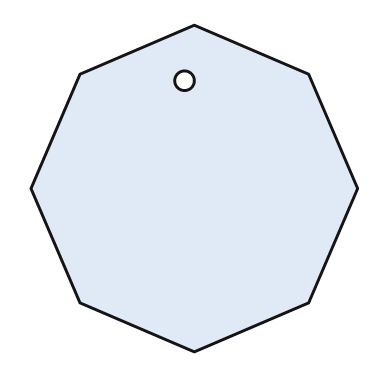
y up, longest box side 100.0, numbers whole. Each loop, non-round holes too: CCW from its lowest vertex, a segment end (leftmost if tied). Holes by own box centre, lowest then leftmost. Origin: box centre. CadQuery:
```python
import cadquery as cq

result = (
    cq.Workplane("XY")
    .moveTo(0.0, -50.0)
    .lineTo(35.0, -35.0)
    .lineTo(50.0, 0.0)
    .lineTo(35.0, 35.0)
    .lineTo(0.0, 50.0)
    .lineTo(-35.0, 35.0)
    .lineTo(-50.0, 0.0)
    .lineTo(-35.0, -35.0)
    .close()
    .moveTo(-3.0, 33.0)
    .circle(3.0)
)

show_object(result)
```